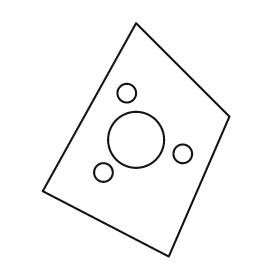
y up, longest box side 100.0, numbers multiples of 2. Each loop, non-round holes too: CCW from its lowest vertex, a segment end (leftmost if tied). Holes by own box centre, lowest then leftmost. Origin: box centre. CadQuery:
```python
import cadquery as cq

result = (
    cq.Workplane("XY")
    .moveTo(14.0, -50.0)
    .lineTo(40.0, 10.0)
    .lineTo(0.0, 50.0)
    .lineTo(-40.0, -22.0)
    .close()
    .moveTo(-14.0, -14.0)
    .circle(4.0)
    .moveTo(20.0, -6.0)
    .circle(4.0)
    .moveTo(0.0, 0.0)
    .circle(12.0)
    .moveTo(-4.0, 20.0)
    .circle(4.0)
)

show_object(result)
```